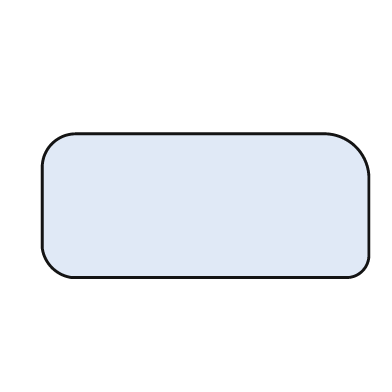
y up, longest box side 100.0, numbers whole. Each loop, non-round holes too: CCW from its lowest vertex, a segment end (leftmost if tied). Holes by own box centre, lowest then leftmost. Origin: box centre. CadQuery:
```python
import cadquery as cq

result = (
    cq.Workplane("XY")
    .moveTo(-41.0, -22.0)
    .lineTo(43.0, -22.0)
    .threePointArc((48.0, -20.0), (50.0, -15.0))
    .lineTo(50.0, 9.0)
    .threePointArc((46.0, 18.0), (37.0, 22.0))
    .lineTo(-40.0, 22.0)
    .threePointArc((-47.0, 19.0), (-50.0, 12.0))
    .lineTo(-50.0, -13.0)
    .threePointArc((-47.0, -19.0), (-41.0, -22.0))
    .close()
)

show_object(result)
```